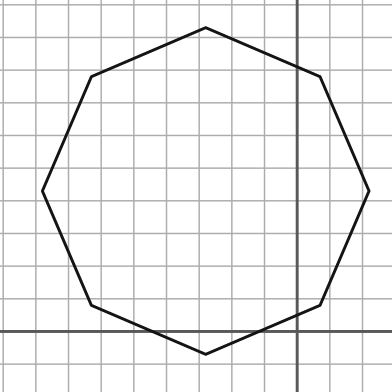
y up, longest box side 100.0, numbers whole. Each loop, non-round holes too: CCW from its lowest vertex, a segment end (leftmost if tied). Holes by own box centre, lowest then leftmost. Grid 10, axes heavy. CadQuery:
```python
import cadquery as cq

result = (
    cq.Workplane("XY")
    .moveTo(-28.0, -7.0)
    .lineTo(7.0, 8.0)
    .lineTo(22.0, 43.0)
    .lineTo(7.0, 78.0)
    .lineTo(-28.0, 93.0)
    .lineTo(-63.0, 78.0)
    .lineTo(-78.0, 43.0)
    .lineTo(-63.0, 8.0)
    .close()
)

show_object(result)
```